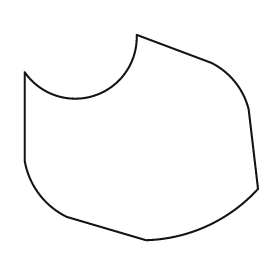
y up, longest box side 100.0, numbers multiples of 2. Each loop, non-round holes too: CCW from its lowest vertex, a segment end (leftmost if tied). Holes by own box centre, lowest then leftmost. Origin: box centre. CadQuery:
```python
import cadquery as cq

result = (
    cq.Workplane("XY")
    .moveTo(2.0, -44.0)
    .threePointArc((28.0, -38.0), (50.0, -22.0))
    .lineTo(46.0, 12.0)
    .threePointArc((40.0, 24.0), (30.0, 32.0))
    .lineTo(-2.0, 44.0)
    .threePointArc((-20.0, 18.0), (-50.0, 28.0))
    .lineTo(-50.0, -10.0)
    .threePointArc((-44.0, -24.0), (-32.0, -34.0))
    .close()
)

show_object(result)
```